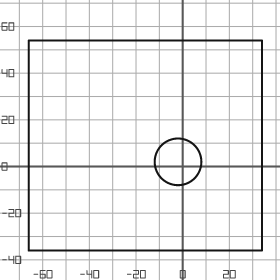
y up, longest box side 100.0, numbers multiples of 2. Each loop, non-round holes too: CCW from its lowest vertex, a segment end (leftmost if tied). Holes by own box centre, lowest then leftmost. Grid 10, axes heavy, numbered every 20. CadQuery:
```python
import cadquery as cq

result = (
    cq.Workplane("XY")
    .moveTo(-66.0, -36.0)
    .lineTo(34.0, -36.0)
    .lineTo(34.0, 54.0)
    .lineTo(-66.0, 54.0)
    .close()
    .moveTo(-2.0, 2.0)
    .circle(10.0)
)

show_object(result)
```